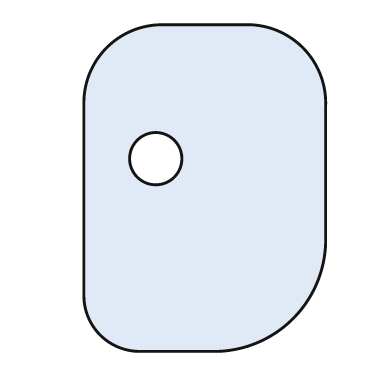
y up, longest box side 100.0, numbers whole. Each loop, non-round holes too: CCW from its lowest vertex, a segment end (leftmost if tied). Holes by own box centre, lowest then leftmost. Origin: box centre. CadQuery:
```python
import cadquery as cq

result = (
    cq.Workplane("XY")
    .moveTo(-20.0, -50.0)
    .lineTo(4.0, -50.0)
    .threePointArc((27.0, -40.0), (37.0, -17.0))
    .lineTo(37.0, 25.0)
    .threePointArc((30.0, 43.0), (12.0, 50.0))
    .lineTo(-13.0, 50.0)
    .threePointArc((-30.0, 43.0), (-37.0, 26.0))
    .lineTo(-37.0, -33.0)
    .threePointArc((-32.0, -45.0), (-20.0, -50.0))
    .close()
    .moveTo(-15.0, 9.0)
    .circle(8.0)
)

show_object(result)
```